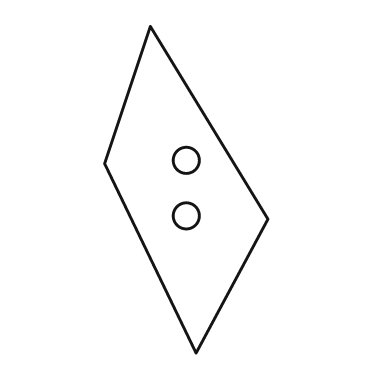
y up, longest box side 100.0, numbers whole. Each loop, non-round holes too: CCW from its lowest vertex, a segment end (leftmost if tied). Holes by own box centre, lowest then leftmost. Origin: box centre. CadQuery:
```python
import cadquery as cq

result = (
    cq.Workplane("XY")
    .moveTo(3.0, -50.0)
    .lineTo(25.0, -9.0)
    .lineTo(-11.0, 50.0)
    .lineTo(-25.0, 8.0)
    .close()
    .moveTo(0.0, -8.0)
    .circle(4.0)
    .moveTo(0.0, 9.0)
    .circle(4.0)
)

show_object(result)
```